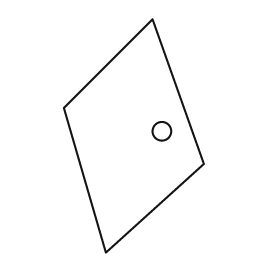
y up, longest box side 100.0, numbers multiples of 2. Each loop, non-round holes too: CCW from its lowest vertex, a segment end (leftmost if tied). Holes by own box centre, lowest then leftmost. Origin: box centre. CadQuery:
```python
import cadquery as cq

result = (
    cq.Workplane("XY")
    .moveTo(-12.0, -50.0)
    .lineTo(30.0, -12.0)
    .lineTo(8.0, 50.0)
    .lineTo(-30.0, 12.0)
    .close()
    .moveTo(12.0, 2.0)
    .circle(4.0)
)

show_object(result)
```